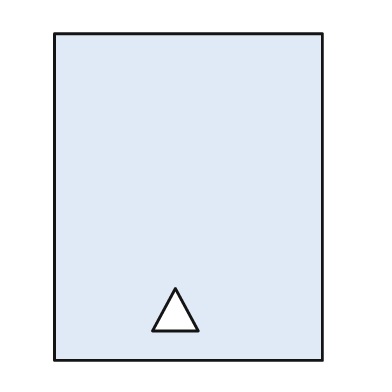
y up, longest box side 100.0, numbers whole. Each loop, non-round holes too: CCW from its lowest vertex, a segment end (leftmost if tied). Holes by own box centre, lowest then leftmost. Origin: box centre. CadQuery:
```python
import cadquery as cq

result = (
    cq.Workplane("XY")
    .moveTo(-41.0, -50.0)
    .lineTo(41.0, -50.0)
    .lineTo(41.0, 50.0)
    .lineTo(-41.0, 50.0)
    .close()
    .moveTo(-11.0, -41.0)
    .lineTo(3.0, -41.0)
    .lineTo(-4.0, -28.0)
    .close()
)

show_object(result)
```